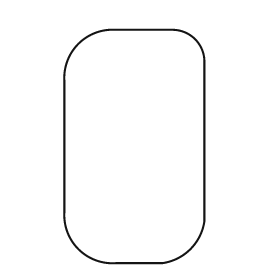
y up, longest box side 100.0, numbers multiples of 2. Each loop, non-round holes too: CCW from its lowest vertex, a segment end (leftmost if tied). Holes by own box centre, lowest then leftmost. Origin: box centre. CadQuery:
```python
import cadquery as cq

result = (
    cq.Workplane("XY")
    .moveTo(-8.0, -50.0)
    .lineTo(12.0, -50.0)
    .threePointArc((24.0, -44.0), (30.0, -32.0))
    .lineTo(30.0, 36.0)
    .threePointArc((26.0, 46.0), (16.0, 50.0))
    .lineTo(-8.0, 50.0)
    .threePointArc((-24.0, 44.0), (-30.0, 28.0))
    .lineTo(-30.0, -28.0)
    .threePointArc((-24.0, -44.0), (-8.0, -50.0))
    .close()
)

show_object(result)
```